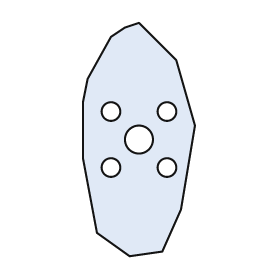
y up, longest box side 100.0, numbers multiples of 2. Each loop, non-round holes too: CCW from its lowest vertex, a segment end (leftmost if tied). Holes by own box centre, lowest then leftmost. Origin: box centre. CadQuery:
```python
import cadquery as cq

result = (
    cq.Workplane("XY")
    .moveTo(-4.0, -50.0)
    .lineTo(10.0, -48.0)
    .lineTo(18.0, -30.0)
    .lineTo(24.0, 6.0)
    .lineTo(16.0, 34.0)
    .lineTo(0.0, 50.0)
    .lineTo(-6.0, 48.0)
    .lineTo(-12.0, 44.0)
    .lineTo(-22.0, 26.0)
    .lineTo(-24.0, 16.0)
    .lineTo(-24.0, -8.0)
    .lineTo(-18.0, -40.0)
    .close()
    .moveTo(-12.0, -12.0)
    .circle(4.0)
    .moveTo(12.0, -12.0)
    .circle(4.0)
    .moveTo(0.0, 0.0)
    .circle(6.0)
    .moveTo(-12.0, 12.0)
    .circle(4.0)
    .moveTo(12.0, 12.0)
    .circle(4.0)
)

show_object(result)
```